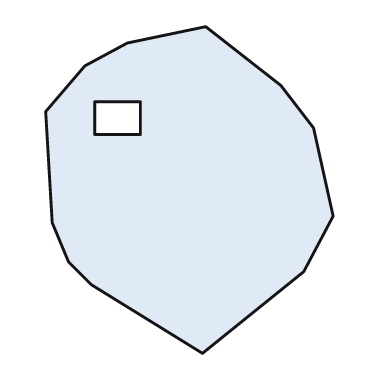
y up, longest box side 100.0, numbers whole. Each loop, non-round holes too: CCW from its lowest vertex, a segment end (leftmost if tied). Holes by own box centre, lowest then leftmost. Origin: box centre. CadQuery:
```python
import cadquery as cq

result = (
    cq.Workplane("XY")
    .moveTo(4.0, -50.0)
    .lineTo(35.0, -25.0)
    .lineTo(44.0, -8.0)
    .lineTo(38.0, 19.0)
    .lineTo(28.0, 32.0)
    .lineTo(5.0, 50.0)
    .lineTo(-19.0, 45.0)
    .lineTo(-32.0, 38.0)
    .lineTo(-44.0, 24.0)
    .lineTo(-42.0, -10.0)
    .lineTo(-37.0, -22.0)
    .lineTo(-30.0, -29.0)
    .close()
    .moveTo(-29.0, 17.0)
    .lineTo(-15.0, 17.0)
    .lineTo(-15.0, 27.0)
    .lineTo(-29.0, 27.0)
    .close()
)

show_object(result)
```